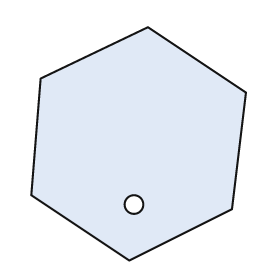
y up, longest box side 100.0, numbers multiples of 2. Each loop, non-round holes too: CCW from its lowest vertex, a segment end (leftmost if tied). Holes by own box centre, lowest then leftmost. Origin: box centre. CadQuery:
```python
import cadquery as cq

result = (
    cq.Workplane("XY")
    .moveTo(-4.0, -50.0)
    .lineTo(40.0, -28.0)
    .lineTo(46.0, 22.0)
    .lineTo(4.0, 50.0)
    .lineTo(-42.0, 28.0)
    .lineTo(-46.0, -22.0)
    .close()
    .moveTo(-2.0, -26.0)
    .circle(4.0)
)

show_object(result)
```